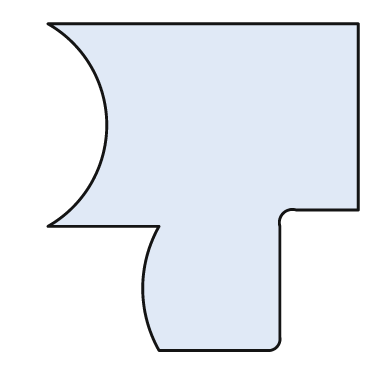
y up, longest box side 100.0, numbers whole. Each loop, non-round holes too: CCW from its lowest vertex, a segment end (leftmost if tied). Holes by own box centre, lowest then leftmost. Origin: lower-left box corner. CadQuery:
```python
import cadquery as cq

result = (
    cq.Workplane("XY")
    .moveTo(34.0, 0.0)
    .lineTo(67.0, 0.0)
    .threePointArc((70.0, 1.0), (71.0, 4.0))
    .lineTo(71.0, 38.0)
    .threePointArc((72.0, 42.0), (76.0, 43.0))
    .lineTo(95.0, 43.0)
    .lineTo(95.0, 100.0)
    .lineTo(0.0, 100.0)
    .threePointArc((18.0, 69.0), (0.0, 38.0))
    .lineTo(34.0, 38.0)
    .threePointArc((29.0, 19.0), (34.0, 0.0))
    .close()
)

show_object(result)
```